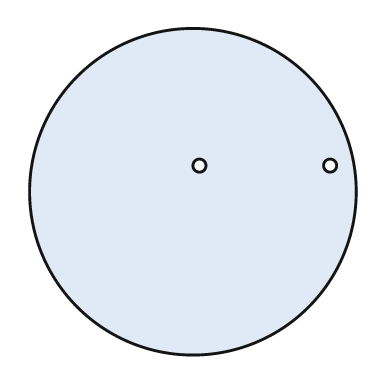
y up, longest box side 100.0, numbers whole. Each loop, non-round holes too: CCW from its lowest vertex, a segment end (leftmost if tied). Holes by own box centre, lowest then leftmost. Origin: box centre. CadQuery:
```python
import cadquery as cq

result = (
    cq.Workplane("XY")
    .moveTo(0.0, 0.0)
    .circle(50.0)
    .moveTo(2.0, 8.0)
    .circle(2.0)
    .moveTo(42.0, 8.0)
    .circle(2.0)
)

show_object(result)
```